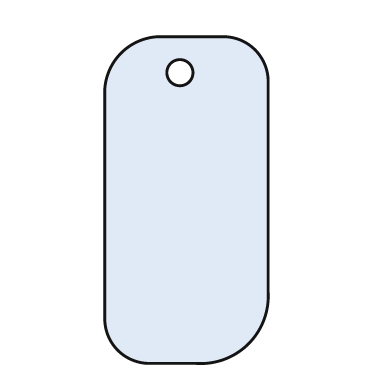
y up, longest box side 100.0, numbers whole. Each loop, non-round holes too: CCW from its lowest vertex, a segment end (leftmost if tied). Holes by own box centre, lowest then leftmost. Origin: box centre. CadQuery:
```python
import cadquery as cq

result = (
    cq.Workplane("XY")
    .moveTo(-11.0, -50.0)
    .lineTo(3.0, -50.0)
    .threePointArc((19.0, -44.0), (25.0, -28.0))
    .lineTo(25.0, 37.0)
    .threePointArc((21.0, 46.0), (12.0, 50.0))
    .lineTo(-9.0, 50.0)
    .threePointArc((-20.0, 45.0), (-25.0, 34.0))
    .lineTo(-25.0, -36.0)
    .threePointArc((-21.0, -46.0), (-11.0, -50.0))
    .close()
    .moveTo(-2.0, 39.0)
    .circle(4.0)
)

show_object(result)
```